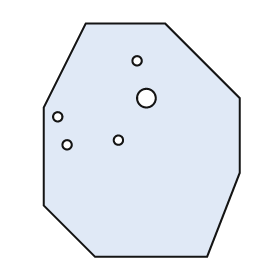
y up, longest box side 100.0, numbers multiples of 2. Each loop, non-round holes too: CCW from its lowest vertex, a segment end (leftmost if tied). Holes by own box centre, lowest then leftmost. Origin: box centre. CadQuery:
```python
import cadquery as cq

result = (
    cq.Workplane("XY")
    .moveTo(-20.0, -50.0)
    .lineTo(28.0, -50.0)
    .lineTo(42.0, -14.0)
    .lineTo(42.0, 18.0)
    .lineTo(10.0, 50.0)
    .lineTo(-24.0, 50.0)
    .lineTo(-42.0, 14.0)
    .lineTo(-42.0, -28.0)
    .close()
    .moveTo(-32.0, -2.0)
    .circle(2.0)
    .moveTo(-10.0, 0.0)
    .circle(2.0)
    .moveTo(-36.0, 10.0)
    .circle(2.0)
    .moveTo(2.0, 18.0)
    .circle(4.0)
    .moveTo(-2.0, 34.0)
    .circle(2.0)
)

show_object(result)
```